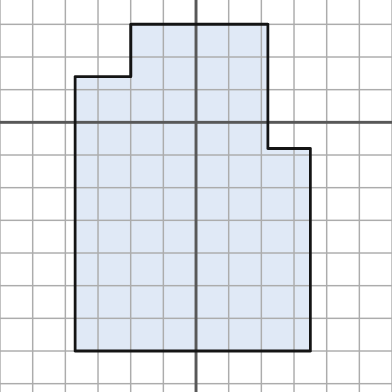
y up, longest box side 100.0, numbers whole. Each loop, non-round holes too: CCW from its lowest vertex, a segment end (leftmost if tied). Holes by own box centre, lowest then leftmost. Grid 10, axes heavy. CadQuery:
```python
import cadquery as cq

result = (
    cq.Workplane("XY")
    .moveTo(-37.0, -70.0)
    .lineTo(35.0, -70.0)
    .lineTo(35.0, -8.0)
    .lineTo(22.0, -8.0)
    .lineTo(22.0, 30.0)
    .lineTo(-20.0, 30.0)
    .lineTo(-20.0, 14.0)
    .lineTo(-37.0, 14.0)
    .close()
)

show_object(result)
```